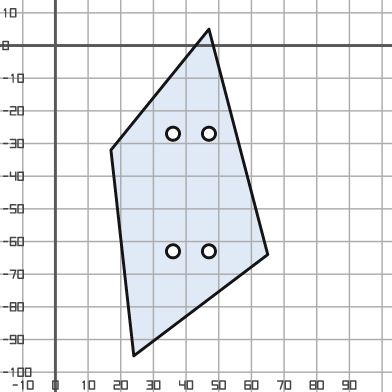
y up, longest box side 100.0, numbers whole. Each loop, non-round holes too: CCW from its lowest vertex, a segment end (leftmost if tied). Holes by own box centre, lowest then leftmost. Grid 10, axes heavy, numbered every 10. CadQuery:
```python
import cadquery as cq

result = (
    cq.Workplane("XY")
    .moveTo(24.0, -95.0)
    .lineTo(65.0, -64.0)
    .lineTo(47.0, 5.0)
    .lineTo(17.0, -32.0)
    .close()
    .moveTo(36.0, -63.0)
    .circle(2.0)
    .moveTo(47.0, -63.0)
    .circle(2.0)
    .moveTo(36.0, -27.0)
    .circle(2.0)
    .moveTo(47.0, -27.0)
    .circle(2.0)
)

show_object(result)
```